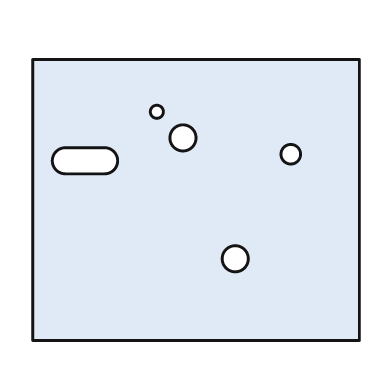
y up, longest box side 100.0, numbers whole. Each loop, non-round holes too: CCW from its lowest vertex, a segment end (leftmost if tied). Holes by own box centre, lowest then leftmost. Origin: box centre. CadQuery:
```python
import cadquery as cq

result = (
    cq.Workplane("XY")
    .moveTo(-50.0, -43.0)
    .lineTo(50.0, -43.0)
    .lineTo(50.0, 43.0)
    .lineTo(-50.0, 43.0)
    .close()
    .moveTo(12.0, -18.0)
    .circle(4.0)
    .moveTo(-40.0, 8.0)
    .lineTo(-28.0, 8.0)
    .threePointArc((-24.0, 12.0), (-28.0, 16.0))
    .lineTo(-40.0, 16.0)
    .threePointArc((-44.0, 12.0), (-40.0, 8.0))
    .close()
    .moveTo(29.0, 14.0)
    .circle(3.0)
    .moveTo(-4.0, 19.0)
    .circle(4.0)
    .moveTo(-12.0, 27.0)
    .circle(2.0)
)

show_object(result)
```